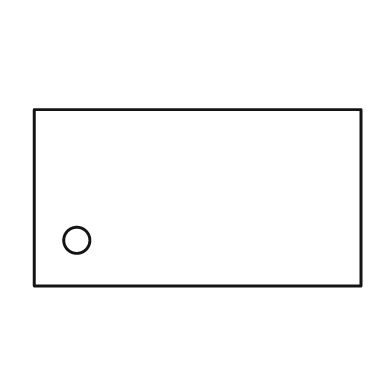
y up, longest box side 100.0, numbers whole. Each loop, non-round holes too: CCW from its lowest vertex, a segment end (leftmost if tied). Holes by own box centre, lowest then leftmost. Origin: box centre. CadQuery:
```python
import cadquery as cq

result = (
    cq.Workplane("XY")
    .moveTo(-50.0, -27.0)
    .lineTo(50.0, -27.0)
    .lineTo(50.0, 27.0)
    .lineTo(-50.0, 27.0)
    .close()
    .moveTo(-37.0, -13.0)
    .circle(4.0)
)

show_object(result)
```